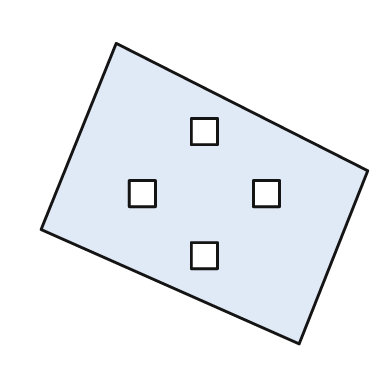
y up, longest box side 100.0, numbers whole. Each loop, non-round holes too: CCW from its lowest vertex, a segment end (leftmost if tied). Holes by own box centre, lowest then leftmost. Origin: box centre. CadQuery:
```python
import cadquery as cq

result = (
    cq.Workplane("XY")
    .moveTo(29.0, -46.0)
    .lineTo(50.0, 7.0)
    .lineTo(-27.0, 46.0)
    .lineTo(-50.0, -11.0)
    .close()
    .moveTo(-4.0, -23.0)
    .lineTo(4.0, -23.0)
    .lineTo(4.0, -15.0)
    .lineTo(-4.0, -15.0)
    .close()
    .moveTo(-23.0, -4.0)
    .lineTo(-15.0, -4.0)
    .lineTo(-15.0, 4.0)
    .lineTo(-23.0, 4.0)
    .close()
    .moveTo(15.0, -4.0)
    .lineTo(23.0, -4.0)
    .lineTo(23.0, 4.0)
    .lineTo(15.0, 4.0)
    .close()
    .moveTo(-4.0, 15.0)
    .lineTo(4.0, 15.0)
    .lineTo(4.0, 23.0)
    .lineTo(-4.0, 23.0)
    .close()
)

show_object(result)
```